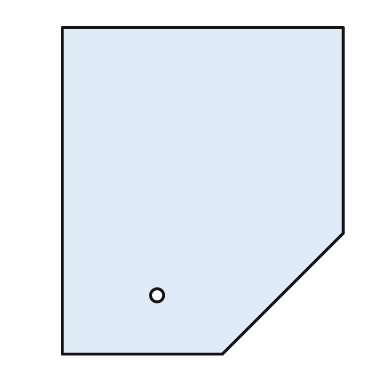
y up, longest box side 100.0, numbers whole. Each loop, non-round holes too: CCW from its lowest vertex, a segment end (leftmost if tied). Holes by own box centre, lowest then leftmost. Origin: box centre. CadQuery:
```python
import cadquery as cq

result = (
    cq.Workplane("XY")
    .moveTo(-43.0, -50.0)
    .lineTo(6.0, -50.0)
    .lineTo(43.0, -13.0)
    .lineTo(43.0, 50.0)
    .lineTo(-43.0, 50.0)
    .close()
    .moveTo(-14.0, -32.0)
    .circle(2.0)
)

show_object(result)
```